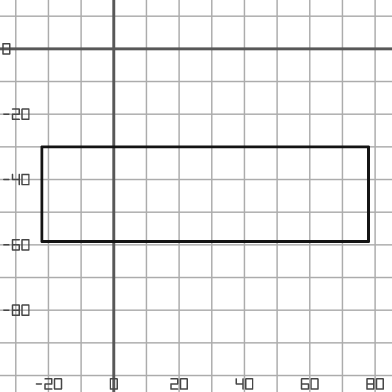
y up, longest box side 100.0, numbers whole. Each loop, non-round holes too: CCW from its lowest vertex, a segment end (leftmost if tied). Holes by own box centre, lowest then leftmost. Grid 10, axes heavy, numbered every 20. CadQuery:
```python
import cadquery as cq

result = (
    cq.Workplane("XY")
    .moveTo(-22.0, -59.0)
    .lineTo(78.0, -59.0)
    .lineTo(78.0, -30.0)
    .lineTo(-22.0, -30.0)
    .close()
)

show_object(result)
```